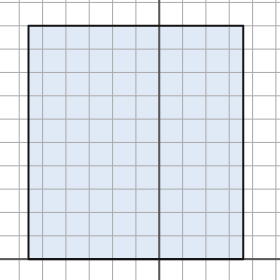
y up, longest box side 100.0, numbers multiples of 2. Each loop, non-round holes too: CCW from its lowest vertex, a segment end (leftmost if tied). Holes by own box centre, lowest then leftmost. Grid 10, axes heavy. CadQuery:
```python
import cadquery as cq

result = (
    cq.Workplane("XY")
    .moveTo(-56.0, 0.0)
    .lineTo(36.0, 0.0)
    .lineTo(36.0, 100.0)
    .lineTo(-56.0, 100.0)
    .close()
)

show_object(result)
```